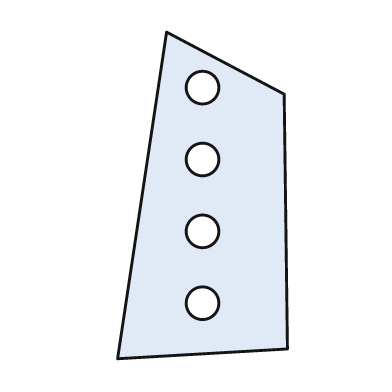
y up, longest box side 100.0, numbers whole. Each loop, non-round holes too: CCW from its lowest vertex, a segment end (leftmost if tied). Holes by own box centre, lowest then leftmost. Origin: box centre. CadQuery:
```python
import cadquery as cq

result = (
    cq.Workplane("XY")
    .moveTo(-26.0, -50.0)
    .lineTo(26.0, -47.0)
    .lineTo(25.0, 31.0)
    .lineTo(-11.0, 50.0)
    .close()
    .moveTo(0.0, -33.0)
    .circle(5.0)
    .moveTo(0.0, -11.0)
    .circle(5.0)
    .moveTo(0.0, 11.0)
    .circle(5.0)
    .moveTo(0.0, 33.0)
    .circle(5.0)
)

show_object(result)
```